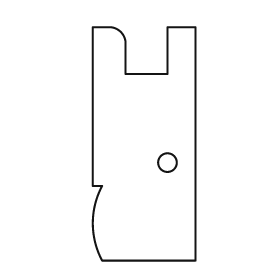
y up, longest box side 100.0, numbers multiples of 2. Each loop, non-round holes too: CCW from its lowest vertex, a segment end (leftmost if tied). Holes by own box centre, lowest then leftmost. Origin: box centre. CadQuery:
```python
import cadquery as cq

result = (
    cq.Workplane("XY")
    .moveTo(-18.0, -50.0)
    .lineTo(22.0, -50.0)
    .lineTo(22.0, 50.0)
    .lineTo(10.0, 50.0)
    .lineTo(10.0, 30.0)
    .lineTo(-8.0, 30.0)
    .lineTo(-8.0, 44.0)
    .threePointArc((-10.0, 48.0), (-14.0, 50.0))
    .lineTo(-22.0, 50.0)
    .lineTo(-22.0, -18.0)
    .lineTo(-18.0, -18.0)
    .threePointArc((-22.0, -34.0), (-18.0, -50.0))
    .close()
    .moveTo(10.0, -8.0)
    .circle(4.0)
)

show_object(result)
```